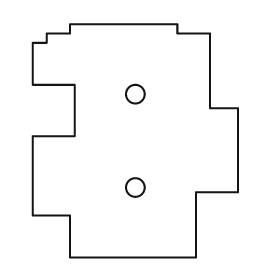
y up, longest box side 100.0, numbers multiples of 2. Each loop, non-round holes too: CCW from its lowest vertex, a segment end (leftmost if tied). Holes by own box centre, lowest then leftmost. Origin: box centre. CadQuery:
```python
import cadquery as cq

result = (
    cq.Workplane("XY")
    .moveTo(-28.0, -50.0)
    .lineTo(26.0, -50.0)
    .lineTo(26.0, -22.0)
    .lineTo(44.0, -22.0)
    .lineTo(44.0, 14.0)
    .lineTo(32.0, 14.0)
    .lineTo(32.0, 46.0)
    .lineTo(18.0, 46.0)
    .lineTo(18.0, 50.0)
    .lineTo(-28.0, 50.0)
    .lineTo(-28.0, 46.0)
    .lineTo(-38.0, 46.0)
    .lineTo(-38.0, 42.0)
    .lineTo(-44.0, 42.0)
    .lineTo(-44.0, 24.0)
    .lineTo(-26.0, 24.0)
    .lineTo(-26.0, 2.0)
    .lineTo(-44.0, 2.0)
    .lineTo(-44.0, -32.0)
    .lineTo(-28.0, -32.0)
    .close()
    .moveTo(0.0, -20.0)
    .circle(4.0)
    .moveTo(0.0, 20.0)
    .circle(4.0)
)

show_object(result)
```